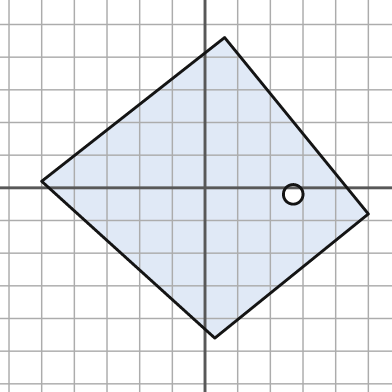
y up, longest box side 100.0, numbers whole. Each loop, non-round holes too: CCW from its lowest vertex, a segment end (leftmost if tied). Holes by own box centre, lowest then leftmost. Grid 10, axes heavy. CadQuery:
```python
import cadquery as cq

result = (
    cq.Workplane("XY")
    .moveTo(3.0, -46.0)
    .lineTo(50.0, -8.0)
    .lineTo(6.0, 46.0)
    .lineTo(-50.0, 2.0)
    .close()
    .moveTo(27.0, -2.0)
    .circle(3.0)
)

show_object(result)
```